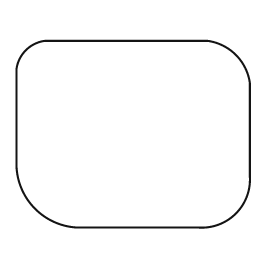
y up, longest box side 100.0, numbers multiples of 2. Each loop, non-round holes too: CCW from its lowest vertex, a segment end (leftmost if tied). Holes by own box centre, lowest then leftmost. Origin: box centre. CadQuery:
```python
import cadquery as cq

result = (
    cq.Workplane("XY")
    .moveTo(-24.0, -40.0)
    .lineTo(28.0, -40.0)
    .threePointArc((44.0, -34.0), (50.0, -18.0))
    .lineTo(50.0, 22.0)
    .threePointArc((44.0, 34.0), (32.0, 40.0))
    .lineTo(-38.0, 40.0)
    .threePointArc((-46.0, 36.0), (-50.0, 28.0))
    .lineTo(-50.0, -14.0)
    .threePointArc((-42.0, -32.0), (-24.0, -40.0))
    .close()
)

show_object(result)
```